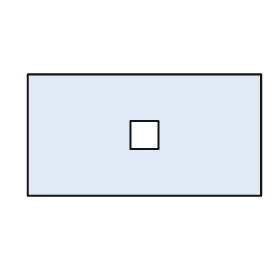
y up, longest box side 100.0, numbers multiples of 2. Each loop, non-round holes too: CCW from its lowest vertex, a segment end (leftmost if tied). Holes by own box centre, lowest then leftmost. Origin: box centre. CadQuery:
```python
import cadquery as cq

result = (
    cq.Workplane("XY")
    .moveTo(-50.0, -26.0)
    .lineTo(50.0, -26.0)
    .lineTo(50.0, 26.0)
    .lineTo(-50.0, 26.0)
    .close()
    .moveTo(-6.0, -6.0)
    .lineTo(6.0, -6.0)
    .lineTo(6.0, 6.0)
    .lineTo(-6.0, 6.0)
    .close()
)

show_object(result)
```